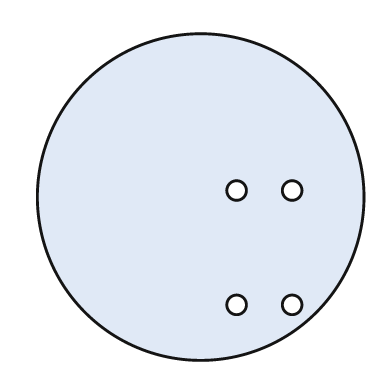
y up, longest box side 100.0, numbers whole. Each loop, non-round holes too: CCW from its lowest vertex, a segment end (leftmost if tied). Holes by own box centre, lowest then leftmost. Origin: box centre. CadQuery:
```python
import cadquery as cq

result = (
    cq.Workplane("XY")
    .moveTo(0.0, 0.0)
    .circle(50.0)
    .moveTo(11.0, -33.0)
    .circle(3.0)
    .moveTo(28.0, -33.0)
    .circle(3.0)
    .moveTo(11.0, 2.0)
    .circle(3.0)
    .moveTo(28.0, 2.0)
    .circle(3.0)
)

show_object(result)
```